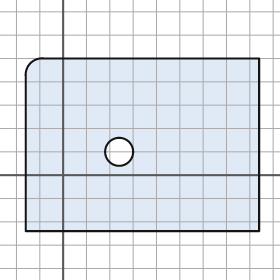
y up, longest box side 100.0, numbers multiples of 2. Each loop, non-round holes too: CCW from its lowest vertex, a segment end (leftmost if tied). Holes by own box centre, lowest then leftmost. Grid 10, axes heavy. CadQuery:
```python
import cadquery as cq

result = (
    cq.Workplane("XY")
    .moveTo(-16.0, -24.0)
    .lineTo(84.0, -24.0)
    .lineTo(84.0, 50.0)
    .lineTo(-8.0, 50.0)
    .threePointArc((-14.0, 48.0), (-16.0, 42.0))
    .close()
    .moveTo(24.0, 10.0)
    .circle(6.0)
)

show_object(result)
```